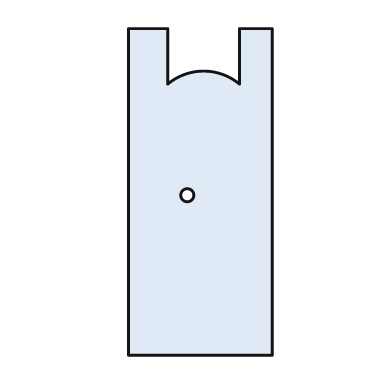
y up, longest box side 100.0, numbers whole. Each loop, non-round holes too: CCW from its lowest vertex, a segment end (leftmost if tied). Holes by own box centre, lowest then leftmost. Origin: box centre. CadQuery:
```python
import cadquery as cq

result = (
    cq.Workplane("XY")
    .moveTo(-22.0, -50.0)
    .lineTo(22.0, -50.0)
    .lineTo(22.0, 50.0)
    .lineTo(12.0, 50.0)
    .lineTo(12.0, 33.0)
    .threePointArc((1.0, 37.0), (-10.0, 33.0))
    .lineTo(-10.0, 50.0)
    .lineTo(-22.0, 50.0)
    .close()
    .moveTo(-4.0, -1.0)
    .circle(2.0)
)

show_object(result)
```